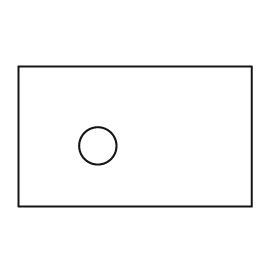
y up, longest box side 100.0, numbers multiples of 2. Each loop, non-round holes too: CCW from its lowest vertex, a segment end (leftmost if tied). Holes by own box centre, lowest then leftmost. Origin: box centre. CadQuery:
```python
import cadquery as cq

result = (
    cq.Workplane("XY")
    .moveTo(-50.0, -30.0)
    .lineTo(50.0, -30.0)
    .lineTo(50.0, 30.0)
    .lineTo(-50.0, 30.0)
    .close()
    .moveTo(-16.0, -4.0)
    .circle(8.0)
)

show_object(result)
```